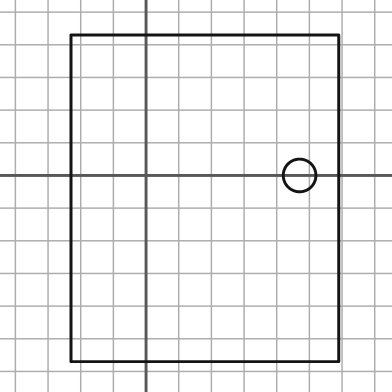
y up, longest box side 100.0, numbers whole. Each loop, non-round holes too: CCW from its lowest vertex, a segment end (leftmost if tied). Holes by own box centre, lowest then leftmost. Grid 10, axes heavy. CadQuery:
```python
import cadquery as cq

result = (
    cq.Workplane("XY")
    .moveTo(-23.0, -57.0)
    .lineTo(59.0, -57.0)
    .lineTo(59.0, 43.0)
    .lineTo(-23.0, 43.0)
    .close()
    .moveTo(47.0, 0.0)
    .circle(5.0)
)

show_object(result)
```